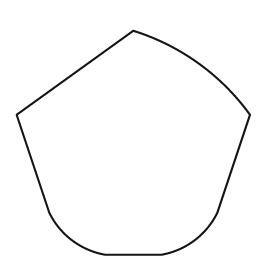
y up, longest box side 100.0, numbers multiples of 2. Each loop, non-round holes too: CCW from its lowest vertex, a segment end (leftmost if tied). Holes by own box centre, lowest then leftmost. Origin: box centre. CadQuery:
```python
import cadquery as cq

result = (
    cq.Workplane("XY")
    .moveTo(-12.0, -48.0)
    .lineTo(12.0, -48.0)
    .threePointArc((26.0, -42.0), (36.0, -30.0))
    .lineTo(50.0, 12.0)
    .threePointArc((28.0, 34.0), (0.0, 48.0))
    .lineTo(-50.0, 12.0)
    .lineTo(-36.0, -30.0)
    .threePointArc((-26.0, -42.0), (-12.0, -48.0))
    .close()
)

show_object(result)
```